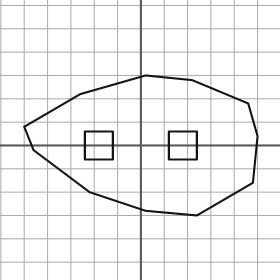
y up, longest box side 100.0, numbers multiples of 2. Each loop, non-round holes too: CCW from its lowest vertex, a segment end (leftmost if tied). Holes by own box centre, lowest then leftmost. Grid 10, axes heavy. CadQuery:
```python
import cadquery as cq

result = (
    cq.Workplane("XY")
    .moveTo(24.0, -30.0)
    .lineTo(48.0, -16.0)
    .lineTo(50.0, 4.0)
    .lineTo(46.0, 18.0)
    .lineTo(22.0, 28.0)
    .lineTo(2.0, 30.0)
    .lineTo(-26.0, 22.0)
    .lineTo(-50.0, 8.0)
    .lineTo(-46.0, -2.0)
    .lineTo(-22.0, -20.0)
    .lineTo(2.0, -28.0)
    .close()
    .moveTo(-24.0, -6.0)
    .lineTo(-12.0, -6.0)
    .lineTo(-12.0, 6.0)
    .lineTo(-24.0, 6.0)
    .close()
    .moveTo(12.0, -6.0)
    .lineTo(24.0, -6.0)
    .lineTo(24.0, 6.0)
    .lineTo(12.0, 6.0)
    .close()
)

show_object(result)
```